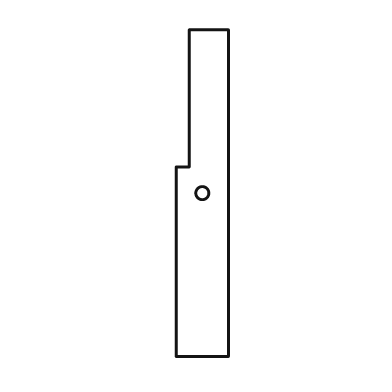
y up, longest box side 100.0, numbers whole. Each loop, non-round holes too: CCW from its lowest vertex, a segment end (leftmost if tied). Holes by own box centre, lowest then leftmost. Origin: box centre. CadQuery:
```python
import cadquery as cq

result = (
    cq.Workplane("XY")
    .moveTo(-8.0, -50.0)
    .lineTo(8.0, -50.0)
    .lineTo(8.0, 50.0)
    .lineTo(-4.0, 50.0)
    .lineTo(-4.0, 8.0)
    .lineTo(-8.0, 8.0)
    .close()
    .moveTo(0.0, 0.0)
    .circle(2.0)
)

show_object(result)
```